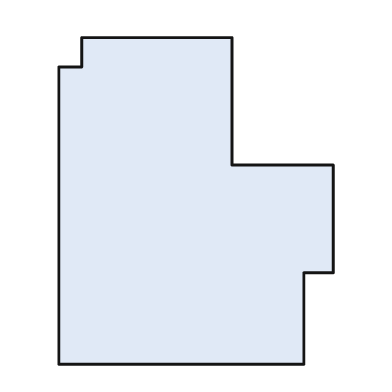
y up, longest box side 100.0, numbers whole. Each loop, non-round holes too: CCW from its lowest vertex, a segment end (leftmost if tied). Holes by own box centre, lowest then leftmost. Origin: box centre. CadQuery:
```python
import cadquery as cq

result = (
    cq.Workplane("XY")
    .moveTo(-42.0, -50.0)
    .lineTo(33.0, -50.0)
    .lineTo(33.0, -22.0)
    .lineTo(42.0, -22.0)
    .lineTo(42.0, 11.0)
    .lineTo(11.0, 11.0)
    .lineTo(11.0, 50.0)
    .lineTo(-35.0, 50.0)
    .lineTo(-35.0, 41.0)
    .lineTo(-42.0, 41.0)
    .close()
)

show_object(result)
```